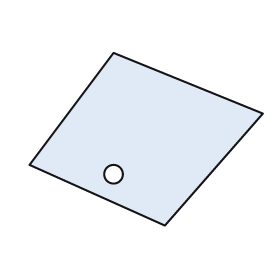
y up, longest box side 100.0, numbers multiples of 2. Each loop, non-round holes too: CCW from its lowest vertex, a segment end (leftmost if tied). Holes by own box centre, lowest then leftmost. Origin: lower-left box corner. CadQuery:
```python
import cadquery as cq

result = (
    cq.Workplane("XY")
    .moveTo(58.0, 0.0)
    .lineTo(100.0, 48.0)
    .lineTo(36.0, 74.0)
    .lineTo(0.0, 26.0)
    .close()
    .moveTo(36.0, 22.0)
    .circle(4.0)
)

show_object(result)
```